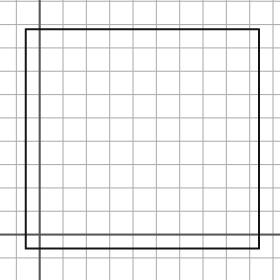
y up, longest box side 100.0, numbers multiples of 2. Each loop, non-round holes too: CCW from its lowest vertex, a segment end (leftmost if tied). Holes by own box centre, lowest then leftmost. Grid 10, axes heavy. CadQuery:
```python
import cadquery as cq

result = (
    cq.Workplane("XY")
    .moveTo(-6.0, -6.0)
    .lineTo(94.0, -6.0)
    .lineTo(94.0, 88.0)
    .lineTo(-6.0, 88.0)
    .close()
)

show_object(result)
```